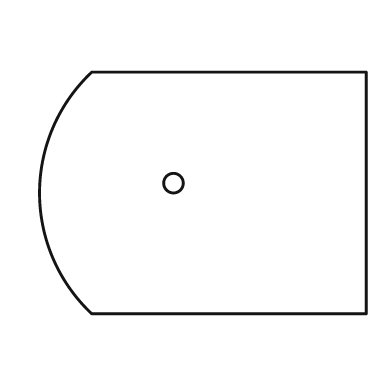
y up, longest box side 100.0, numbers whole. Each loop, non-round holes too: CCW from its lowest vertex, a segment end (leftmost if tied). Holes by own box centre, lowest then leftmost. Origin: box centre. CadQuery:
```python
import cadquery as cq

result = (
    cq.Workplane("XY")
    .moveTo(-34.0, -37.0)
    .lineTo(50.0, -37.0)
    .lineTo(50.0, 37.0)
    .lineTo(-34.0, 37.0)
    .threePointArc((-50.0, 0.0), (-34.0, -37.0))
    .close()
    .moveTo(-9.0, 3.0)
    .circle(3.0)
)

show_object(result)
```